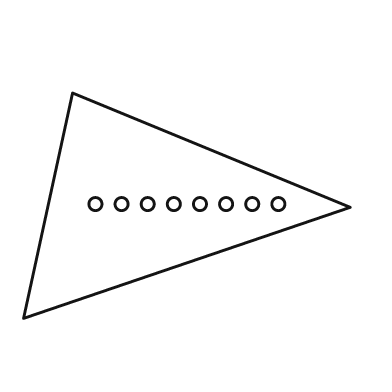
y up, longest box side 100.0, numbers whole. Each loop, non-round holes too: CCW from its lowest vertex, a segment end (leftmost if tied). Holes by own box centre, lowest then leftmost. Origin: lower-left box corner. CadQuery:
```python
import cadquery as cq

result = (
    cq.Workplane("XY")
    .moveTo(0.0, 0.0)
    .lineTo(100.0, 34.0)
    .lineTo(15.0, 69.0)
    .close()
    .moveTo(22.0, 35.0)
    .circle(2.0)
    .moveTo(30.0, 35.0)
    .circle(2.0)
    .moveTo(38.0, 35.0)
    .circle(2.0)
    .moveTo(46.0, 35.0)
    .circle(2.0)
    .moveTo(54.0, 35.0)
    .circle(2.0)
    .moveTo(62.0, 35.0)
    .circle(2.0)
    .moveTo(70.0, 35.0)
    .circle(2.0)
    .moveTo(78.0, 35.0)
    .circle(2.0)
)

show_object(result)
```